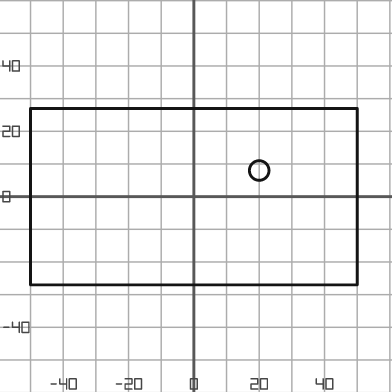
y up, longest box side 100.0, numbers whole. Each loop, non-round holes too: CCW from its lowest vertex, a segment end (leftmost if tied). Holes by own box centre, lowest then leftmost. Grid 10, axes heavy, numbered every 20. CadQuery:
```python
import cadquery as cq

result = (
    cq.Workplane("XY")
    .moveTo(-50.0, -27.0)
    .lineTo(50.0, -27.0)
    .lineTo(50.0, 27.0)
    .lineTo(-50.0, 27.0)
    .close()
    .moveTo(20.0, 8.0)
    .circle(3.0)
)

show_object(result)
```